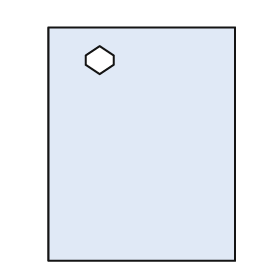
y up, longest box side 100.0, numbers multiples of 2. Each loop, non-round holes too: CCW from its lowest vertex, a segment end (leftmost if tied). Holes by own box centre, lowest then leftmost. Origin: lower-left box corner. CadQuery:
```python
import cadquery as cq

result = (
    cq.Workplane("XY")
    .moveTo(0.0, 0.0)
    .lineTo(80.0, 0.0)
    .lineTo(80.0, 100.0)
    .lineTo(0.0, 100.0)
    .close()
    .moveTo(22.0, 80.0)
    .lineTo(28.0, 84.0)
    .lineTo(28.0, 88.0)
    .lineTo(22.0, 92.0)
    .lineTo(16.0, 88.0)
    .lineTo(16.0, 84.0)
    .close()
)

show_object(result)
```